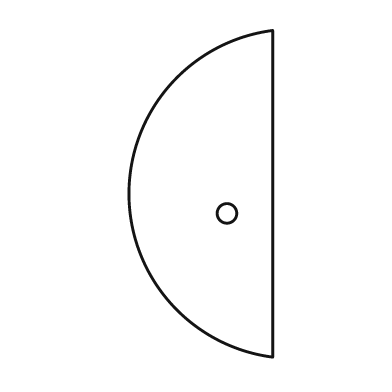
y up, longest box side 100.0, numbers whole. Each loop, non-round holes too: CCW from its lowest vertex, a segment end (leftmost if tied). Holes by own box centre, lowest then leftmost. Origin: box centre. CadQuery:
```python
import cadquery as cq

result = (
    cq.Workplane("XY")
    .moveTo(22.0, -50.0)
    .lineTo(22.0, 50.0)
    .threePointArc((-22.0, 0.0), (22.0, -50.0))
    .close()
    .moveTo(8.0, -6.0)
    .circle(3.0)
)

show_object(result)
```